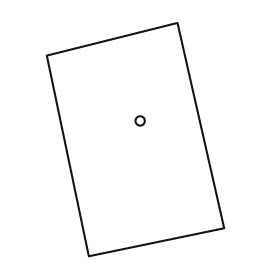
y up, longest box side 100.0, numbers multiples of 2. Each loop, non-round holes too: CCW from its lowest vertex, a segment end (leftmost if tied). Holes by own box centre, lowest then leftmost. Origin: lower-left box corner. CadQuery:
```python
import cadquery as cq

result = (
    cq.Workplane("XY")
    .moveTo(18.0, 0.0)
    .lineTo(76.0, 12.0)
    .lineTo(56.0, 100.0)
    .lineTo(0.0, 86.0)
    .close()
    .moveTo(40.0, 58.0)
    .circle(2.0)
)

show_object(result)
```